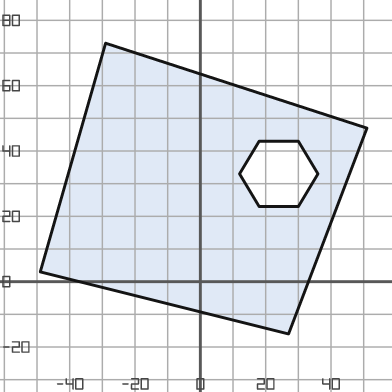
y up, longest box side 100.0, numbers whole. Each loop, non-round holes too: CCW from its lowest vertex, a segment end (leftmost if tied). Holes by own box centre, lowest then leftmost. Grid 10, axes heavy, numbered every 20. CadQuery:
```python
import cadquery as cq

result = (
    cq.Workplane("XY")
    .moveTo(27.0, -16.0)
    .lineTo(51.0, 47.0)
    .lineTo(-29.0, 73.0)
    .lineTo(-49.0, 3.0)
    .close()
    .moveTo(18.0, 23.0)
    .lineTo(30.0, 23.0)
    .lineTo(36.0, 33.0)
    .lineTo(30.0, 43.0)
    .lineTo(18.0, 43.0)
    .lineTo(12.0, 33.0)
    .close()
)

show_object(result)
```